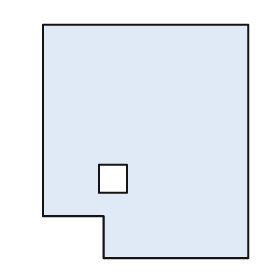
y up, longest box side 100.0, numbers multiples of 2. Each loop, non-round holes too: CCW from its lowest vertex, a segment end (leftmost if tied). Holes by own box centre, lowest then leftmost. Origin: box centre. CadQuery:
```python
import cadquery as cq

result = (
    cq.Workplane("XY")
    .moveTo(-18.0, -50.0)
    .lineTo(44.0, -50.0)
    .lineTo(44.0, 50.0)
    .lineTo(-44.0, 50.0)
    .lineTo(-44.0, -32.0)
    .lineTo(-18.0, -32.0)
    .close()
    .moveTo(-20.0, -22.0)
    .lineTo(-8.0, -22.0)
    .lineTo(-8.0, -10.0)
    .lineTo(-20.0, -10.0)
    .close()
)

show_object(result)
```